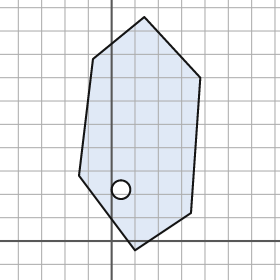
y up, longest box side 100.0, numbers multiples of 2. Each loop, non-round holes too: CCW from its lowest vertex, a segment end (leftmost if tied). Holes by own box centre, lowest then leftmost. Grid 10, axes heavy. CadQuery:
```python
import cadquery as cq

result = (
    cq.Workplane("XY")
    .moveTo(10.0, -4.0)
    .lineTo(34.0, 12.0)
    .lineTo(38.0, 70.0)
    .lineTo(14.0, 96.0)
    .lineTo(-8.0, 78.0)
    .lineTo(-14.0, 28.0)
    .close()
    .moveTo(4.0, 22.0)
    .circle(4.0)
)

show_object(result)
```